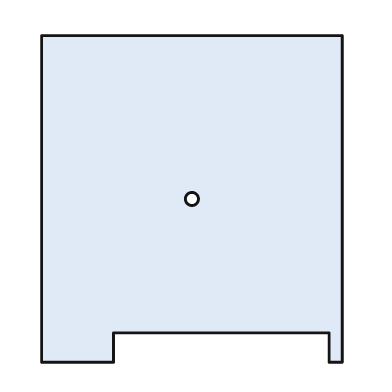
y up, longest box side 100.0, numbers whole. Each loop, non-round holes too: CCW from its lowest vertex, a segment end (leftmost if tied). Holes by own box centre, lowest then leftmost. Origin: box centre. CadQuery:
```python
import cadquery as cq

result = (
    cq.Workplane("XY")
    .moveTo(-46.0, -50.0)
    .lineTo(-24.0, -50.0)
    .lineTo(-24.0, -41.0)
    .lineTo(42.0, -41.0)
    .lineTo(42.0, -50.0)
    .lineTo(46.0, -50.0)
    .lineTo(46.0, 50.0)
    .lineTo(-46.0, 50.0)
    .close()
    .moveTo(0.0, 0.0)
    .circle(2.0)
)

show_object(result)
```